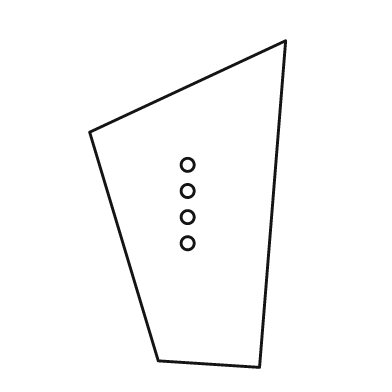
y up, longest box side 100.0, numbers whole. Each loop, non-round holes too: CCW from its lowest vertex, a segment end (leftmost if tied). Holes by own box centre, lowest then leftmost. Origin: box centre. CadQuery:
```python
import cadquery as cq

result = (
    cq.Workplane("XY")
    .moveTo(22.0, -50.0)
    .lineTo(30.0, 50.0)
    .lineTo(-30.0, 22.0)
    .lineTo(-9.0, -48.0)
    .close()
    .moveTo(0.0, -12.0)
    .circle(2.0)
    .moveTo(0.0, -4.0)
    .circle(2.0)
    .moveTo(0.0, 4.0)
    .circle(2.0)
    .moveTo(0.0, 12.0)
    .circle(2.0)
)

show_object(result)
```